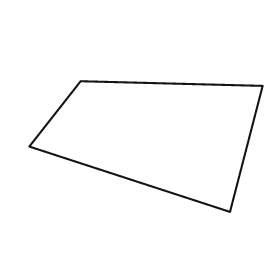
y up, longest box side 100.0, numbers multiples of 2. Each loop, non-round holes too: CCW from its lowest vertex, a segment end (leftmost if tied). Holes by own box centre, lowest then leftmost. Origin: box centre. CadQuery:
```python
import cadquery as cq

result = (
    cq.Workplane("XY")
    .moveTo(36.0, -28.0)
    .lineTo(50.0, 26.0)
    .lineTo(-28.0, 28.0)
    .lineTo(-50.0, 0.0)
    .close()
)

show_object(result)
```